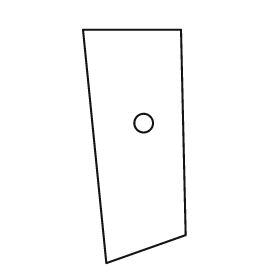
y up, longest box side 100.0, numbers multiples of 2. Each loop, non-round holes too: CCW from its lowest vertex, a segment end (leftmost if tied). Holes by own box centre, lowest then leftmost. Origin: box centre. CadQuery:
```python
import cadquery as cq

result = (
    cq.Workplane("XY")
    .moveTo(-12.0, -50.0)
    .lineTo(22.0, -38.0)
    .lineTo(20.0, 50.0)
    .lineTo(-22.0, 50.0)
    .close()
    .moveTo(4.0, 10.0)
    .circle(4.0)
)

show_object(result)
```